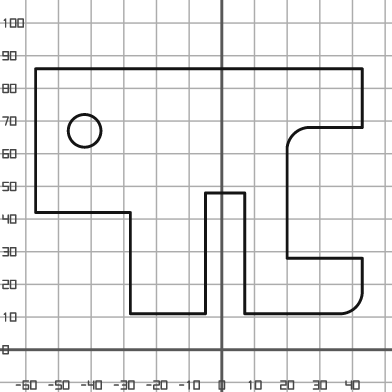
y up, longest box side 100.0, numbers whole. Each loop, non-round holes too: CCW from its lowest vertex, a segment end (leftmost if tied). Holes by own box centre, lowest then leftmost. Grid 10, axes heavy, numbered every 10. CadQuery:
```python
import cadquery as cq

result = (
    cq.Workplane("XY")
    .moveTo(-28.0, 11.0)
    .lineTo(-5.0, 11.0)
    .lineTo(-5.0, 48.0)
    .lineTo(7.0, 48.0)
    .lineTo(7.0, 11.0)
    .lineTo(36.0, 11.0)
    .threePointArc((41.0, 13.0), (43.0, 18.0))
    .lineTo(43.0, 28.0)
    .lineTo(20.0, 28.0)
    .lineTo(20.0, 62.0)
    .threePointArc((22.0, 66.0), (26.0, 68.0))
    .lineTo(43.0, 68.0)
    .lineTo(43.0, 86.0)
    .lineTo(-57.0, 86.0)
    .lineTo(-57.0, 42.0)
    .lineTo(-28.0, 42.0)
    .close()
    .moveTo(-42.0, 67.0)
    .circle(5.0)
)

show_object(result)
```